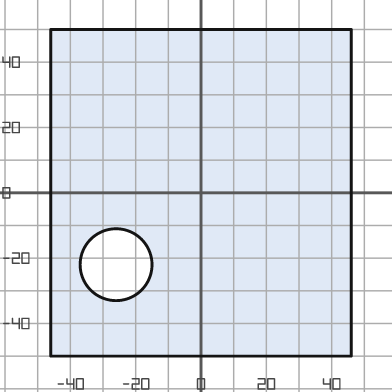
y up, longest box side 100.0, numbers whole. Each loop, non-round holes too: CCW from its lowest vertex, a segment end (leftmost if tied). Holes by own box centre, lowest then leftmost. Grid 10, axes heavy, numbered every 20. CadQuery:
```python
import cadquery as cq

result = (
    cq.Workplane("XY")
    .moveTo(-46.0, -50.0)
    .lineTo(46.0, -50.0)
    .lineTo(46.0, 50.0)
    .lineTo(-46.0, 50.0)
    .close()
    .moveTo(-26.0, -22.0)
    .circle(11.0)
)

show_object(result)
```